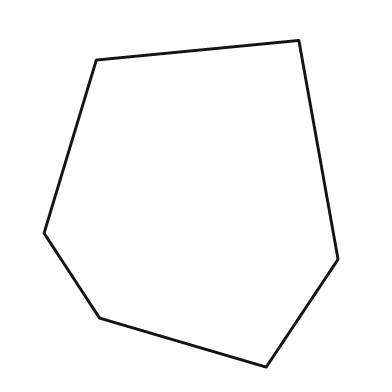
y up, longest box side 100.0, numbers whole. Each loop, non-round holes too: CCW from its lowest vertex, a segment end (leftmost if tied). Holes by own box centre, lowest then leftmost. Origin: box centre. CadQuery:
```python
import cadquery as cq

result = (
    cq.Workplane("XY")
    .moveTo(23.0, -50.0)
    .lineTo(45.0, -17.0)
    .lineTo(33.0, 50.0)
    .lineTo(-29.0, 44.0)
    .lineTo(-45.0, -9.0)
    .lineTo(-28.0, -35.0)
    .close()
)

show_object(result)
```